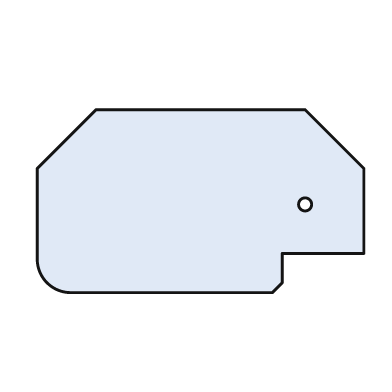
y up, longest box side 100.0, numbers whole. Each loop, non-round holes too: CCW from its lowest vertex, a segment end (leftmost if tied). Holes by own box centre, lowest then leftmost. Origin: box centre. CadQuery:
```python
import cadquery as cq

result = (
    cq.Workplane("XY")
    .moveTo(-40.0, -28.0)
    .lineTo(22.0, -28.0)
    .lineTo(25.0, -25.0)
    .lineTo(25.0, -16.0)
    .lineTo(50.0, -16.0)
    .lineTo(50.0, 10.0)
    .lineTo(32.0, 28.0)
    .lineTo(-32.0, 28.0)
    .lineTo(-50.0, 10.0)
    .lineTo(-50.0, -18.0)
    .threePointArc((-47.0, -25.0), (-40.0, -28.0))
    .close()
    .moveTo(32.0, -1.0)
    .circle(2.0)
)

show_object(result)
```